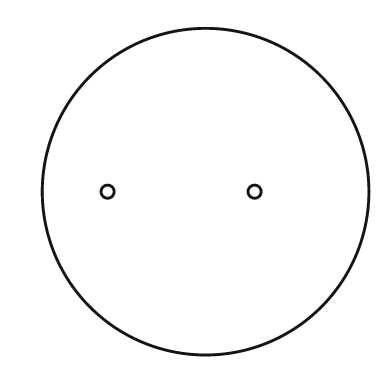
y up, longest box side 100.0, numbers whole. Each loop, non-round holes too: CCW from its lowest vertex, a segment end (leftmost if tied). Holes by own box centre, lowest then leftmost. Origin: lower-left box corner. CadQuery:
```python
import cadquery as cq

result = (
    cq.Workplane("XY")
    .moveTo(50.0, 50.0)
    .circle(50.0)
    .moveTo(20.0, 50.0)
    .circle(2.0)
    .moveTo(65.0, 50.0)
    .circle(2.0)
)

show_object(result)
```